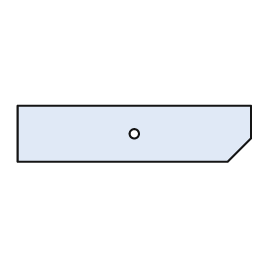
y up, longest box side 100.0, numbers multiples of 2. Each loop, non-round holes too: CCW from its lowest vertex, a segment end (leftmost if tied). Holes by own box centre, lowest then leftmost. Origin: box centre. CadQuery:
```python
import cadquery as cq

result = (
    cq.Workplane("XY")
    .moveTo(-50.0, -12.0)
    .lineTo(40.0, -12.0)
    .lineTo(50.0, -2.0)
    .lineTo(50.0, 12.0)
    .lineTo(-50.0, 12.0)
    .close()
    .moveTo(0.0, 0.0)
    .circle(2.0)
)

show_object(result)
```